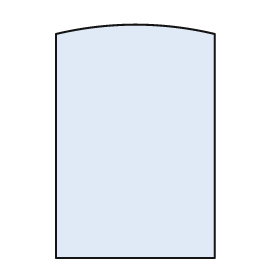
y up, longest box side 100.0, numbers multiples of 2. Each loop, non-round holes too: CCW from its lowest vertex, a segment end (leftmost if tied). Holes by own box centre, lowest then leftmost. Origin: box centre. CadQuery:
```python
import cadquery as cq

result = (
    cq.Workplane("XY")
    .moveTo(-34.0, -50.0)
    .lineTo(34.0, -50.0)
    .lineTo(34.0, 46.0)
    .threePointArc((0.0, 50.0), (-34.0, 46.0))
    .close()
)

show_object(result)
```